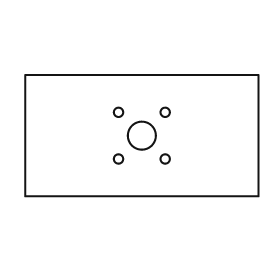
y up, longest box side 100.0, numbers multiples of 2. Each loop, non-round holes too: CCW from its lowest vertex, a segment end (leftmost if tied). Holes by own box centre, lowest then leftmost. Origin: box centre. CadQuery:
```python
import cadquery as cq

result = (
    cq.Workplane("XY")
    .moveTo(-50.0, -26.0)
    .lineTo(50.0, -26.0)
    .lineTo(50.0, 26.0)
    .lineTo(-50.0, 26.0)
    .close()
    .moveTo(-10.0, -10.0)
    .circle(2.0)
    .moveTo(10.0, -10.0)
    .circle(2.0)
    .moveTo(0.0, 0.0)
    .circle(6.0)
    .moveTo(-10.0, 10.0)
    .circle(2.0)
    .moveTo(10.0, 10.0)
    .circle(2.0)
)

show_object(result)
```